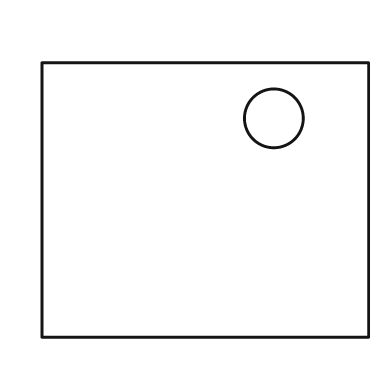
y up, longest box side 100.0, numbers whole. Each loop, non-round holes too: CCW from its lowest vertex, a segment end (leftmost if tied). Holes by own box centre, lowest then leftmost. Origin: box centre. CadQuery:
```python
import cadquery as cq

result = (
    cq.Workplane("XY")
    .moveTo(-50.0, -42.0)
    .lineTo(50.0, -42.0)
    .lineTo(50.0, 42.0)
    .lineTo(-50.0, 42.0)
    .close()
    .moveTo(21.0, 25.0)
    .circle(9.0)
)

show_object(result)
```